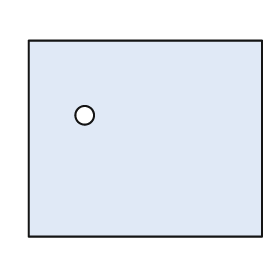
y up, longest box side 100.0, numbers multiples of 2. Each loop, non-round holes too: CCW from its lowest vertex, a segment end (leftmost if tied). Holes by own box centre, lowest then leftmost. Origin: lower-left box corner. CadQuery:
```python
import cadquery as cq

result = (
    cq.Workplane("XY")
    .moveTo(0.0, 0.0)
    .lineTo(100.0, 0.0)
    .lineTo(100.0, 84.0)
    .lineTo(0.0, 84.0)
    .close()
    .moveTo(24.0, 52.0)
    .circle(4.0)
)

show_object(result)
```